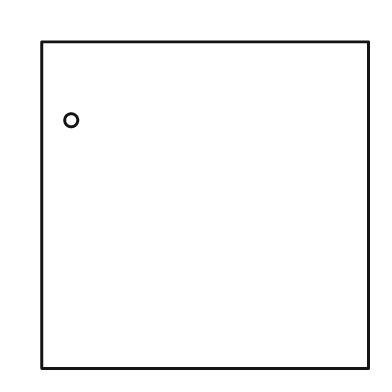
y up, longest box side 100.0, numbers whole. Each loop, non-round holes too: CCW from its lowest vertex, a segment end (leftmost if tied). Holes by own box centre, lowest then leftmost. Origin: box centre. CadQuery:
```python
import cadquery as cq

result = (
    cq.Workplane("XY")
    .moveTo(-50.0, -50.0)
    .lineTo(50.0, -50.0)
    .lineTo(50.0, 50.0)
    .lineTo(-50.0, 50.0)
    .close()
    .moveTo(-41.0, 26.0)
    .circle(2.0)
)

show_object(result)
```